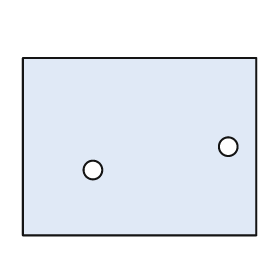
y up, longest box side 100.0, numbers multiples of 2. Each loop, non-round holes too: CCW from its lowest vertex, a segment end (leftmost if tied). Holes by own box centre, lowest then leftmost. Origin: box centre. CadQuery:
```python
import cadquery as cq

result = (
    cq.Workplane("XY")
    .moveTo(-50.0, -38.0)
    .lineTo(50.0, -38.0)
    .lineTo(50.0, 38.0)
    .lineTo(-50.0, 38.0)
    .close()
    .moveTo(-20.0, -10.0)
    .circle(4.0)
    .moveTo(38.0, 0.0)
    .circle(4.0)
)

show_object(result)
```